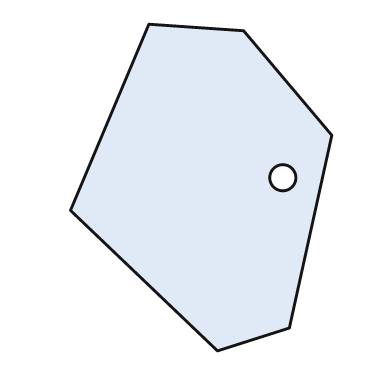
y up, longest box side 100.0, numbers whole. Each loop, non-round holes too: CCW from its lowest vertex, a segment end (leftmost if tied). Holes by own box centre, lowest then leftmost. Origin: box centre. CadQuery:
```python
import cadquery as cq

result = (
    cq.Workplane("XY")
    .moveTo(5.0, -50.0)
    .lineTo(27.0, -43.0)
    .lineTo(40.0, 16.0)
    .lineTo(13.0, 48.0)
    .lineTo(-16.0, 50.0)
    .lineTo(-40.0, -7.0)
    .close()
    .moveTo(25.0, 3.0)
    .circle(4.0)
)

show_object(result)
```